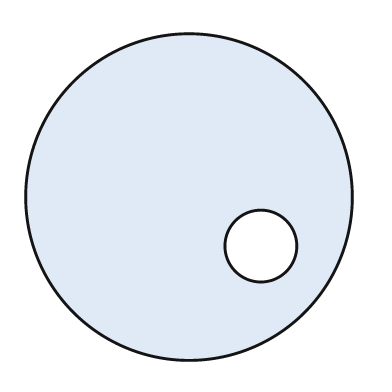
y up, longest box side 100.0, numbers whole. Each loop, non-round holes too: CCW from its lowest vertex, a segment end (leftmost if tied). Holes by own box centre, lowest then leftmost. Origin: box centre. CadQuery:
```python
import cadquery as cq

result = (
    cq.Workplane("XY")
    .moveTo(0.0, 0.0)
    .circle(50.0)
    .moveTo(22.0, -15.0)
    .circle(11.0)
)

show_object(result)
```